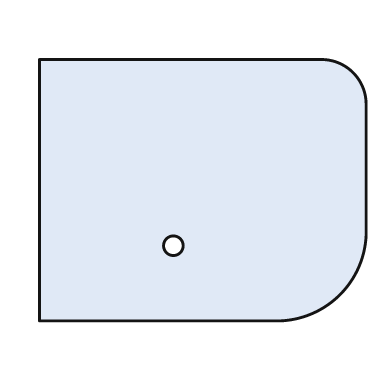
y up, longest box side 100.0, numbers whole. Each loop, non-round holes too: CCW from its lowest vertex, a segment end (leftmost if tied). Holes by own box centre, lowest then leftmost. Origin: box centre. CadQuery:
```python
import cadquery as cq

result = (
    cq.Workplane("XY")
    .moveTo(-50.0, -40.0)
    .lineTo(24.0, -40.0)
    .threePointArc((42.0, -32.0), (50.0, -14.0))
    .lineTo(50.0, 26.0)
    .threePointArc((46.0, 36.0), (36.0, 40.0))
    .lineTo(-50.0, 40.0)
    .close()
    .moveTo(-9.0, -17.0)
    .circle(3.0)
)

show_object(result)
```